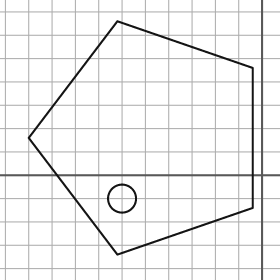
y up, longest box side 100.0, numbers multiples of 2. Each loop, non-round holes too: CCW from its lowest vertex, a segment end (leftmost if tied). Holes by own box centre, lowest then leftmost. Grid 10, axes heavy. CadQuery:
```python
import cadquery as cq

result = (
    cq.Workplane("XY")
    .moveTo(-62.0, -34.0)
    .lineTo(-4.0, -14.0)
    .lineTo(-4.0, 46.0)
    .lineTo(-62.0, 66.0)
    .lineTo(-100.0, 16.0)
    .close()
    .moveTo(-60.0, -10.0)
    .circle(6.0)
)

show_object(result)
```